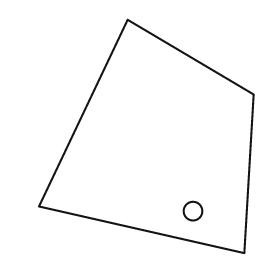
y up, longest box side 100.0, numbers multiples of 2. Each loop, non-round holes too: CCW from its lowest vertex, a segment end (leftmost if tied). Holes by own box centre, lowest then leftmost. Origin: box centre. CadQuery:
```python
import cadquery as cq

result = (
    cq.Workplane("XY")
    .moveTo(42.0, -50.0)
    .lineTo(46.0, 18.0)
    .lineTo(-8.0, 50.0)
    .lineTo(-46.0, -30.0)
    .close()
    .moveTo(20.0, -32.0)
    .circle(4.0)
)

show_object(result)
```